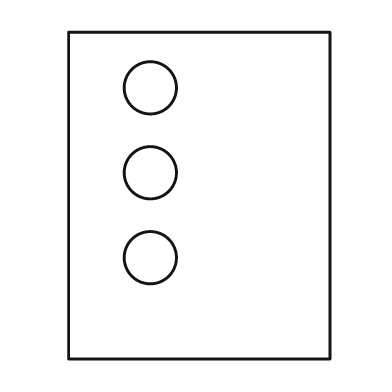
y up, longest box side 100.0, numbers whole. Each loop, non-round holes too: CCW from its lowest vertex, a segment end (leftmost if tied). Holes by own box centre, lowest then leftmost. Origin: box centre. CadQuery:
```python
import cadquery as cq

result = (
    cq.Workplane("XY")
    .moveTo(-40.0, -50.0)
    .lineTo(40.0, -50.0)
    .lineTo(40.0, 50.0)
    .lineTo(-40.0, 50.0)
    .close()
    .moveTo(-15.0, -19.0)
    .circle(8.0)
    .moveTo(-15.0, 7.0)
    .circle(8.0)
    .moveTo(-15.0, 33.0)
    .circle(8.0)
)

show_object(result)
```